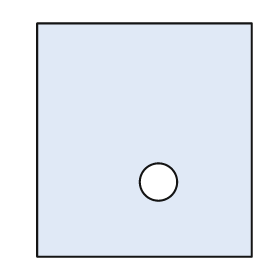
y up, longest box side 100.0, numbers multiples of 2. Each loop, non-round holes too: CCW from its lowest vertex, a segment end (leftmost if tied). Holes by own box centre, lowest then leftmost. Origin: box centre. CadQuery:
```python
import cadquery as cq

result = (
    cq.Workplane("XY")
    .moveTo(-46.0, -50.0)
    .lineTo(46.0, -50.0)
    .lineTo(46.0, 50.0)
    .lineTo(-46.0, 50.0)
    .close()
    .moveTo(6.0, -18.0)
    .circle(8.0)
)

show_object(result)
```